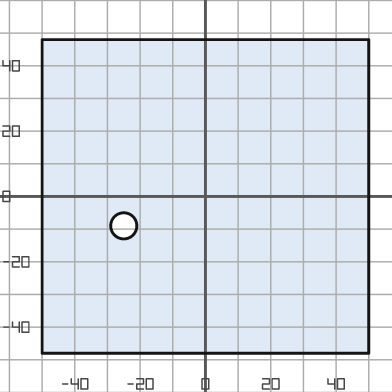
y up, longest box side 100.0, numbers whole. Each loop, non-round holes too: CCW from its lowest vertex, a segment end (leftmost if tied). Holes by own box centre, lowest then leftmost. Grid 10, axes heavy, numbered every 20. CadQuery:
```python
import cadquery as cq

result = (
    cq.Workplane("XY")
    .moveTo(-50.0, -48.0)
    .lineTo(50.0, -48.0)
    .lineTo(50.0, 48.0)
    .lineTo(-50.0, 48.0)
    .close()
    .moveTo(-25.0, -9.0)
    .circle(4.0)
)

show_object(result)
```